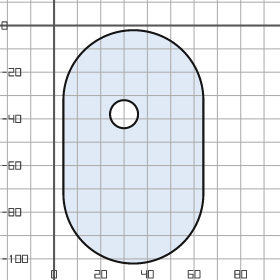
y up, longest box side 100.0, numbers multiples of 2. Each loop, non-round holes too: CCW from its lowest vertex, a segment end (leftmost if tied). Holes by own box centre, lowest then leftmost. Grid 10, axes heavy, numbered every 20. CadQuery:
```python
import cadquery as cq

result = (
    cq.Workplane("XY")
    .moveTo(4.0, -72.0)
    .threePointArc((34.0, -102.0), (64.0, -72.0))
    .lineTo(64.0, -32.0)
    .threePointArc((34.0, -2.0), (4.0, -32.0))
    .close()
    .moveTo(30.0, -38.0)
    .circle(6.0)
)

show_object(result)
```